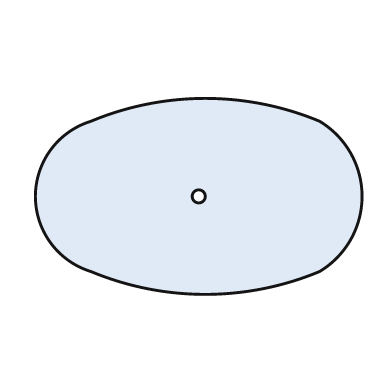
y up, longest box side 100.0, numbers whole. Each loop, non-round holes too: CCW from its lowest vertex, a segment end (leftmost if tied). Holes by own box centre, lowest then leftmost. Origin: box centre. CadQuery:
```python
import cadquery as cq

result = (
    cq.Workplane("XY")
    .moveTo(-33.0, -23.0)
    .threePointArc((2.0, -30.0), (37.0, -23.0))
    .threePointArc((50.0, 0.0), (37.0, 23.0))
    .threePointArc((2.0, 30.0), (-33.0, 23.0))
    .threePointArc((-50.0, 0.0), (-33.0, -23.0))
    .close()
    .moveTo(0.0, 0.0)
    .circle(2.0)
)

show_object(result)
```